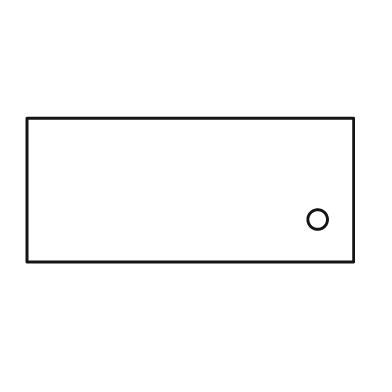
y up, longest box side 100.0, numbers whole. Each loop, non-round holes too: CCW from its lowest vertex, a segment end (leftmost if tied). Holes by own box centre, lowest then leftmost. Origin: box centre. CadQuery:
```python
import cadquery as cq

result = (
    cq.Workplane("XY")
    .moveTo(-50.0, -22.0)
    .lineTo(50.0, -22.0)
    .lineTo(50.0, 22.0)
    .lineTo(-50.0, 22.0)
    .close()
    .moveTo(39.0, -9.0)
    .circle(3.0)
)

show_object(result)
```